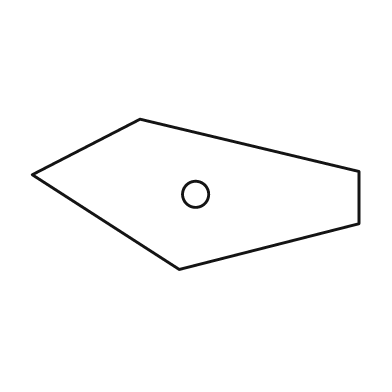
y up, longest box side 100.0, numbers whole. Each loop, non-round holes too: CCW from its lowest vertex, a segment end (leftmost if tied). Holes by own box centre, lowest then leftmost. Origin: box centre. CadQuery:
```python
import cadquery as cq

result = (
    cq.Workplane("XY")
    .moveTo(-5.0, -23.0)
    .lineTo(50.0, -9.0)
    .lineTo(50.0, 7.0)
    .lineTo(-17.0, 23.0)
    .lineTo(-50.0, 6.0)
    .close()
    .moveTo(0.0, 0.0)
    .circle(4.0)
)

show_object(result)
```